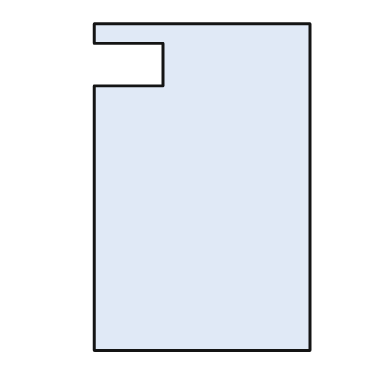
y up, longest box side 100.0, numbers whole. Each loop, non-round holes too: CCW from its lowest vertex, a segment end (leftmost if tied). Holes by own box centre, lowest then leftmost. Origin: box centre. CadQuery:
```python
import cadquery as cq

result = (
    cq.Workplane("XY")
    .moveTo(-33.0, -50.0)
    .lineTo(33.0, -50.0)
    .lineTo(33.0, 50.0)
    .lineTo(-33.0, 50.0)
    .lineTo(-33.0, 44.0)
    .lineTo(-12.0, 44.0)
    .lineTo(-12.0, 31.0)
    .lineTo(-33.0, 31.0)
    .close()
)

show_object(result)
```